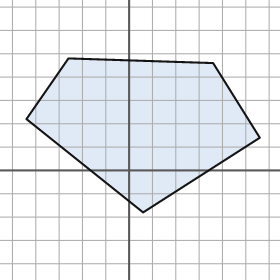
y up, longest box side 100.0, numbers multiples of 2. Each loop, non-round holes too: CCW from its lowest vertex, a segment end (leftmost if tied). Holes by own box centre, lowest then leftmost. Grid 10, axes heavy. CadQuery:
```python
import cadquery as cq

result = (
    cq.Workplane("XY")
    .moveTo(6.0, -18.0)
    .lineTo(56.0, 14.0)
    .lineTo(36.0, 46.0)
    .lineTo(-26.0, 48.0)
    .lineTo(-44.0, 22.0)
    .close()
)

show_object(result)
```